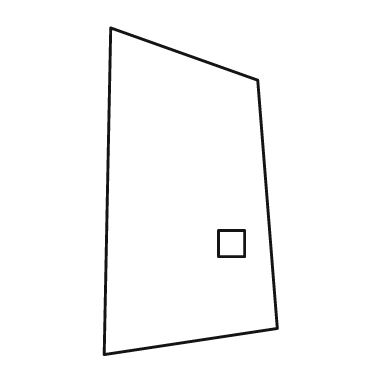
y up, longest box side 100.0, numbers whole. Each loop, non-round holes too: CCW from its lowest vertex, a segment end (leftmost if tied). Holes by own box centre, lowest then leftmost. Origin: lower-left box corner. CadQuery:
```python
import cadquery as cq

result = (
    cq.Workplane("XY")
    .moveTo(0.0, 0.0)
    .lineTo(53.0, 8.0)
    .lineTo(47.0, 84.0)
    .lineTo(2.0, 100.0)
    .close()
    .moveTo(35.0, 30.0)
    .lineTo(43.0, 30.0)
    .lineTo(43.0, 38.0)
    .lineTo(35.0, 38.0)
    .close()
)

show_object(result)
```